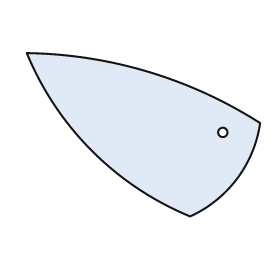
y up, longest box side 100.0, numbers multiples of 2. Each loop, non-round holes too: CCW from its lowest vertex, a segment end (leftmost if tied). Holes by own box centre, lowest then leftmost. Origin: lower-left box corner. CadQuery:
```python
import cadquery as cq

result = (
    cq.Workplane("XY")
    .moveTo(70.0, 0.0)
    .threePointArc((90.0, 16.0), (100.0, 40.0))
    .threePointArc((52.0, 62.0), (0.0, 70.0))
    .threePointArc((28.0, 28.0), (70.0, 0.0))
    .close()
    .moveTo(84.0, 36.0)
    .circle(2.0)
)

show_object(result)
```